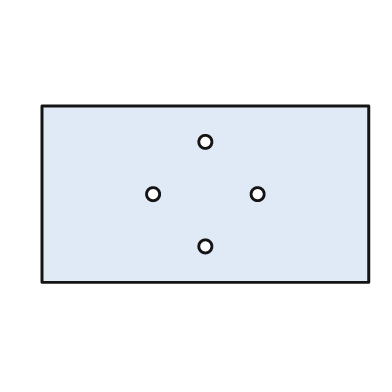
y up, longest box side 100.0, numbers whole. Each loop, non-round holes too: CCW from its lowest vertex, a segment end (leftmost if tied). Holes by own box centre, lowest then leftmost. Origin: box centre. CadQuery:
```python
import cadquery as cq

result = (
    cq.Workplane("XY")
    .moveTo(-50.0, -27.0)
    .lineTo(50.0, -27.0)
    .lineTo(50.0, 27.0)
    .lineTo(-50.0, 27.0)
    .close()
    .moveTo(0.0, -16.0)
    .circle(2.0)
    .moveTo(-16.0, 0.0)
    .circle(2.0)
    .moveTo(16.0, 0.0)
    .circle(2.0)
    .moveTo(0.0, 16.0)
    .circle(2.0)
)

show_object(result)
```